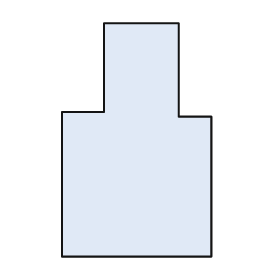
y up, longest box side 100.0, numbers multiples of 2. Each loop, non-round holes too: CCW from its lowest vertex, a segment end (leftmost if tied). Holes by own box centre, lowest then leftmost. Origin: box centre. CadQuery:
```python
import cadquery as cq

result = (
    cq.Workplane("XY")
    .moveTo(-32.0, -50.0)
    .lineTo(32.0, -50.0)
    .lineTo(32.0, 10.0)
    .lineTo(18.0, 10.0)
    .lineTo(18.0, 50.0)
    .lineTo(-14.0, 50.0)
    .lineTo(-14.0, 12.0)
    .lineTo(-32.0, 12.0)
    .close()
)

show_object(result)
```